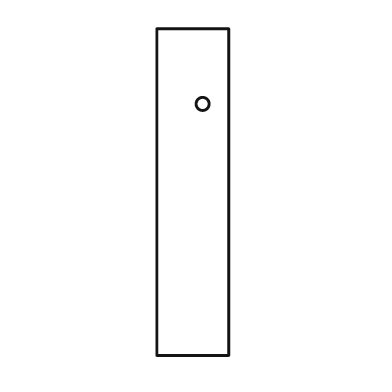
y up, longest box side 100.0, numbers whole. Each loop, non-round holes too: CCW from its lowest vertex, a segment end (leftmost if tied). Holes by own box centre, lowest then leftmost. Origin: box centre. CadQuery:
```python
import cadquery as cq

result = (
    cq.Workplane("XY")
    .moveTo(-11.0, -50.0)
    .lineTo(11.0, -50.0)
    .lineTo(11.0, 50.0)
    .lineTo(-11.0, 50.0)
    .close()
    .moveTo(3.0, 27.0)
    .circle(2.0)
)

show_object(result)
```